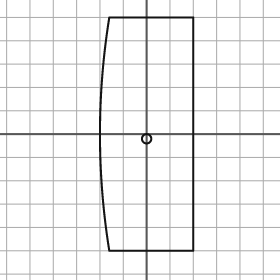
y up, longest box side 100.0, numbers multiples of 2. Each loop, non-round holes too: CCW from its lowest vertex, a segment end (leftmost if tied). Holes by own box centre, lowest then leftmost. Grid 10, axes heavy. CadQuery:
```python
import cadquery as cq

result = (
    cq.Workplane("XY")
    .moveTo(-16.0, -50.0)
    .lineTo(20.0, -50.0)
    .lineTo(20.0, 50.0)
    .lineTo(-16.0, 50.0)
    .threePointArc((-20.0, 0.0), (-16.0, -50.0))
    .close()
    .moveTo(0.0, -2.0)
    .circle(2.0)
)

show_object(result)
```